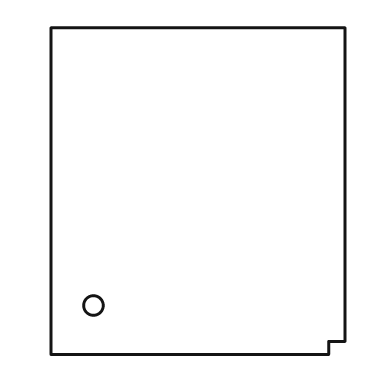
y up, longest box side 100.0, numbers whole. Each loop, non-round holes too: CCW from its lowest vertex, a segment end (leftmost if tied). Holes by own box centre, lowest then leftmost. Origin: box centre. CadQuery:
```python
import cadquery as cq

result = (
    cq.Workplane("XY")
    .moveTo(-45.0, -50.0)
    .lineTo(40.0, -50.0)
    .lineTo(40.0, -46.0)
    .lineTo(45.0, -46.0)
    .lineTo(45.0, 50.0)
    .lineTo(-45.0, 50.0)
    .close()
    .moveTo(-32.0, -35.0)
    .circle(3.0)
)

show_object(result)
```